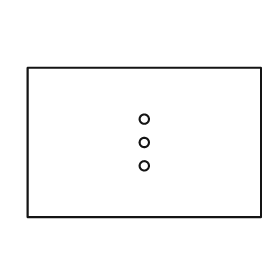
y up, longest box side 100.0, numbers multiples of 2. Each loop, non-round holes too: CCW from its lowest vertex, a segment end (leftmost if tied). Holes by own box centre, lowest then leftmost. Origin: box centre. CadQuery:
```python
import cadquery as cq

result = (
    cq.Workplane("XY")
    .moveTo(-50.0, -32.0)
    .lineTo(50.0, -32.0)
    .lineTo(50.0, 32.0)
    .lineTo(-50.0, 32.0)
    .close()
    .moveTo(0.0, -10.0)
    .circle(2.0)
    .moveTo(0.0, 0.0)
    .circle(2.0)
    .moveTo(0.0, 10.0)
    .circle(2.0)
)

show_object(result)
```